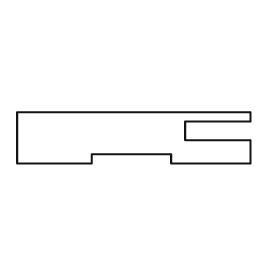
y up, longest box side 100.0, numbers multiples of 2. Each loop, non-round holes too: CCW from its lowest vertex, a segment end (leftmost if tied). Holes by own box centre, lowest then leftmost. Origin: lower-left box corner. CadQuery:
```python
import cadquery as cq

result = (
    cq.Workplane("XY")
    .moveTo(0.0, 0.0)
    .lineTo(32.0, 0.0)
    .lineTo(32.0, 4.0)
    .lineTo(66.0, 4.0)
    .lineTo(66.0, 0.0)
    .lineTo(100.0, 0.0)
    .lineTo(100.0, 10.0)
    .lineTo(72.0, 10.0)
    .lineTo(72.0, 18.0)
    .lineTo(100.0, 18.0)
    .lineTo(100.0, 22.0)
    .lineTo(0.0, 22.0)
    .close()
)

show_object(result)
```